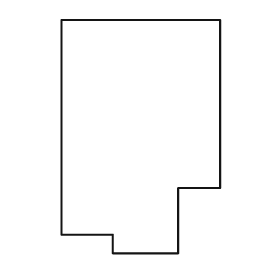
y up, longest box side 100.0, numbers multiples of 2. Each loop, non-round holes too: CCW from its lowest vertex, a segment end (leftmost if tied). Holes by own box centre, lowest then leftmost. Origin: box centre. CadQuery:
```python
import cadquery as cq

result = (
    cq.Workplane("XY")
    .moveTo(-12.0, -50.0)
    .lineTo(16.0, -50.0)
    .lineTo(16.0, -22.0)
    .lineTo(34.0, -22.0)
    .lineTo(34.0, 50.0)
    .lineTo(-34.0, 50.0)
    .lineTo(-34.0, -42.0)
    .lineTo(-12.0, -42.0)
    .close()
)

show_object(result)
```